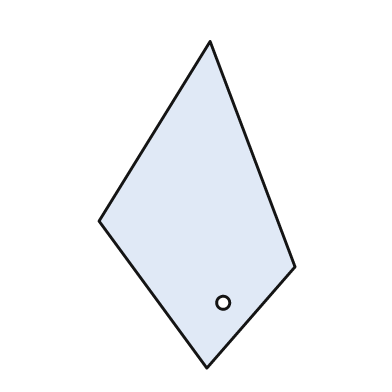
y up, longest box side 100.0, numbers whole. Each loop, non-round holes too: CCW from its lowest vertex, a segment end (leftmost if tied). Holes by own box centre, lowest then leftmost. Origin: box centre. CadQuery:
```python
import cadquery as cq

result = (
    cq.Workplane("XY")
    .moveTo(3.0, -50.0)
    .lineTo(30.0, -19.0)
    .lineTo(4.0, 50.0)
    .lineTo(-30.0, -5.0)
    .close()
    .moveTo(8.0, -30.0)
    .circle(2.0)
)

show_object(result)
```